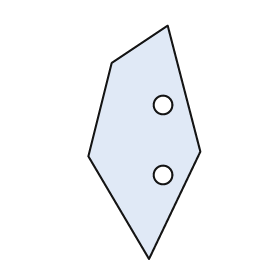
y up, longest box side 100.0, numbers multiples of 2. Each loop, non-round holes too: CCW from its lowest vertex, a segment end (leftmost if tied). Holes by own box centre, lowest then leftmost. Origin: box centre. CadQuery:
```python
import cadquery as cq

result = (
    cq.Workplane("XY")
    .moveTo(2.0, -50.0)
    .lineTo(24.0, -4.0)
    .lineTo(10.0, 50.0)
    .lineTo(-14.0, 34.0)
    .lineTo(-24.0, -6.0)
    .close()
    .moveTo(8.0, -14.0)
    .circle(4.0)
    .moveTo(8.0, 16.0)
    .circle(4.0)
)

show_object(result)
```